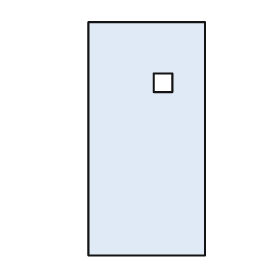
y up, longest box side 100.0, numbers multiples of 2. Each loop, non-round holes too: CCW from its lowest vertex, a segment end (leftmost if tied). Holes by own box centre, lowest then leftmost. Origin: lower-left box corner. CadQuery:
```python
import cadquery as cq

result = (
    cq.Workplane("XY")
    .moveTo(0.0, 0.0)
    .lineTo(50.0, 0.0)
    .lineTo(50.0, 100.0)
    .lineTo(0.0, 100.0)
    .close()
    .moveTo(28.0, 70.0)
    .lineTo(36.0, 70.0)
    .lineTo(36.0, 78.0)
    .lineTo(28.0, 78.0)
    .close()
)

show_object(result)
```